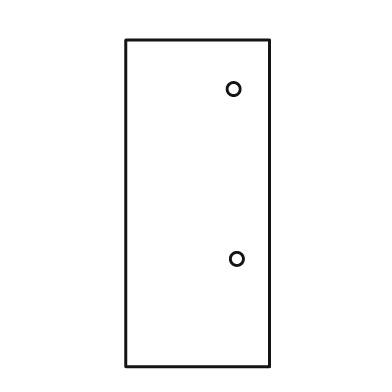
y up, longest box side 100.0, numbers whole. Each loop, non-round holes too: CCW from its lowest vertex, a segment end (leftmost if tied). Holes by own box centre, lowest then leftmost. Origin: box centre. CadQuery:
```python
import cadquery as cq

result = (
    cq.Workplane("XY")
    .moveTo(-22.0, -50.0)
    .lineTo(22.0, -50.0)
    .lineTo(22.0, 50.0)
    .lineTo(-22.0, 50.0)
    .close()
    .moveTo(12.0, -17.0)
    .circle(2.0)
    .moveTo(11.0, 35.0)
    .circle(2.0)
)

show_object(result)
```